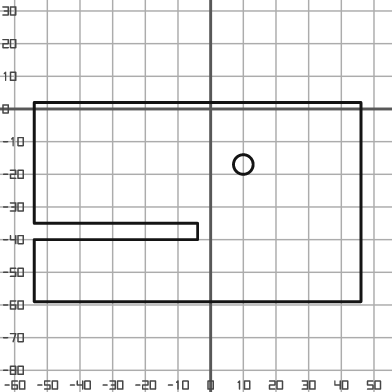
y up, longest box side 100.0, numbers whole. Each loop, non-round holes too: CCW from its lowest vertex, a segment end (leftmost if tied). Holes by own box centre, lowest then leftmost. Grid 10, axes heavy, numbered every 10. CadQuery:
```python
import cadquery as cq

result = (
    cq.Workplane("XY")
    .moveTo(-54.0, -59.0)
    .lineTo(46.0, -59.0)
    .lineTo(46.0, 2.0)
    .lineTo(-54.0, 2.0)
    .lineTo(-54.0, -35.0)
    .lineTo(-4.0, -35.0)
    .lineTo(-4.0, -40.0)
    .lineTo(-54.0, -40.0)
    .close()
    .moveTo(10.0, -17.0)
    .circle(3.0)
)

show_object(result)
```